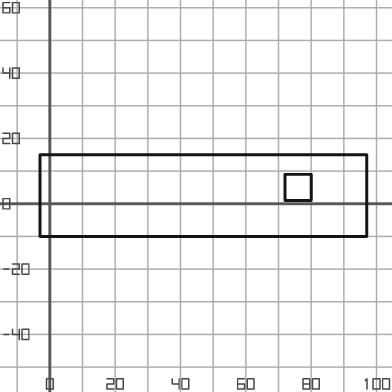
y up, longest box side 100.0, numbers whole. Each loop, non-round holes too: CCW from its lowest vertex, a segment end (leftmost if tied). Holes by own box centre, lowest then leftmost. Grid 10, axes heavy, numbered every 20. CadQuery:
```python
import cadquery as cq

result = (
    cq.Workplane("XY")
    .moveTo(-3.0, -10.0)
    .lineTo(97.0, -10.0)
    .lineTo(97.0, 15.0)
    .lineTo(-3.0, 15.0)
    .close()
    .moveTo(72.0, 1.0)
    .lineTo(80.0, 1.0)
    .lineTo(80.0, 9.0)
    .lineTo(72.0, 9.0)
    .close()
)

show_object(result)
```